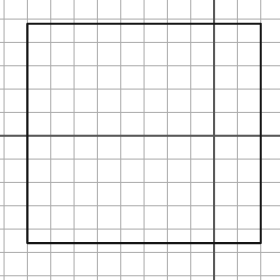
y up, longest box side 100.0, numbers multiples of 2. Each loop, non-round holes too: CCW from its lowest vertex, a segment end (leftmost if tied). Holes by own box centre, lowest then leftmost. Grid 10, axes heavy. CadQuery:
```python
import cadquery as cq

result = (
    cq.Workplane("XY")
    .moveTo(-80.0, -46.0)
    .lineTo(20.0, -46.0)
    .lineTo(20.0, 48.0)
    .lineTo(-80.0, 48.0)
    .close()
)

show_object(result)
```